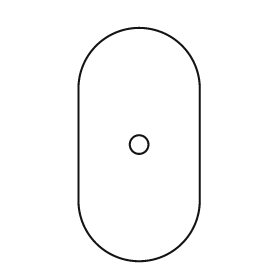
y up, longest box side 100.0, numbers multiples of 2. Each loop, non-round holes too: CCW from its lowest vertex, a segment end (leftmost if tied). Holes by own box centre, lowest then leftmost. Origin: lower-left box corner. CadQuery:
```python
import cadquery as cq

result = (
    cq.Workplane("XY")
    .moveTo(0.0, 26.0)
    .threePointArc((26.0, 0.0), (52.0, 26.0))
    .lineTo(52.0, 74.0)
    .threePointArc((26.0, 100.0), (0.0, 74.0))
    .close()
    .moveTo(26.0, 50.0)
    .circle(4.0)
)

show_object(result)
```